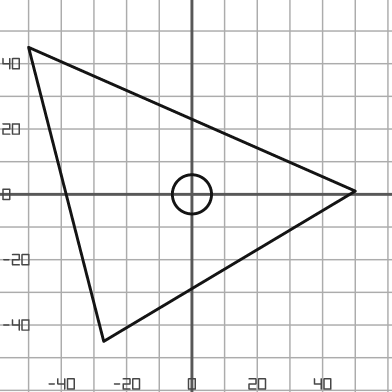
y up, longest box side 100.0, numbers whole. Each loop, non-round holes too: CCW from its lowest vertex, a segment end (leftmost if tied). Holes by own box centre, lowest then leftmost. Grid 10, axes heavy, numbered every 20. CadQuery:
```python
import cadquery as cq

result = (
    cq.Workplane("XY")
    .moveTo(-27.0, -45.0)
    .lineTo(50.0, 1.0)
    .lineTo(-50.0, 45.0)
    .close()
    .moveTo(0.0, 0.0)
    .circle(6.0)
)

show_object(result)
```